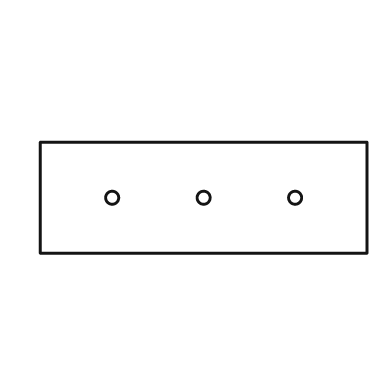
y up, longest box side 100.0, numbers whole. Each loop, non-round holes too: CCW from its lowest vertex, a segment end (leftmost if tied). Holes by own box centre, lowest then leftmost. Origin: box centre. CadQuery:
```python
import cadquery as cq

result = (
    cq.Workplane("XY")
    .moveTo(-50.0, -17.0)
    .lineTo(50.0, -17.0)
    .lineTo(50.0, 17.0)
    .lineTo(-50.0, 17.0)
    .close()
    .moveTo(-28.0, 0.0)
    .circle(2.0)
    .moveTo(0.0, 0.0)
    .circle(2.0)
    .moveTo(28.0, 0.0)
    .circle(2.0)
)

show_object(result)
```